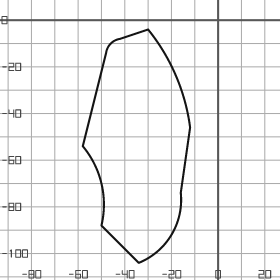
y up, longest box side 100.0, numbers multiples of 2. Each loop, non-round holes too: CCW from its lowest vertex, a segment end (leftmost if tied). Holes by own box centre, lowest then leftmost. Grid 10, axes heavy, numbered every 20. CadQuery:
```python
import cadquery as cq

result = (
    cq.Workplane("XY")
    .moveTo(-34.0, -104.0)
    .threePointArc((-20.0, -92.0), (-16.0, -74.0))
    .lineTo(-12.0, -46.0)
    .threePointArc((-18.0, -24.0), (-30.0, -4.0))
    .lineTo(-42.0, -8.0)
    .threePointArc((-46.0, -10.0), (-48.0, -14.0))
    .lineTo(-58.0, -54.0)
    .threePointArc((-50.0, -70.0), (-50.0, -88.0))
    .close()
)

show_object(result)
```